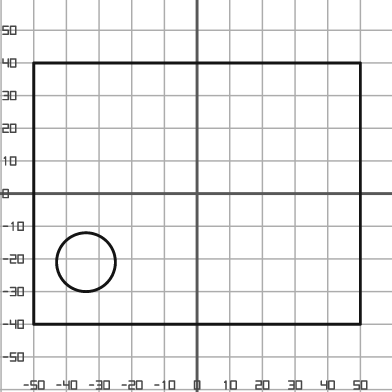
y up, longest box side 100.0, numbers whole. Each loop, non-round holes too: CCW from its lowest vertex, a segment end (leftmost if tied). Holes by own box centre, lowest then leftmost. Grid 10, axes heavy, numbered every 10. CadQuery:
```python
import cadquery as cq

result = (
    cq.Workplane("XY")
    .moveTo(-50.0, -40.0)
    .lineTo(50.0, -40.0)
    .lineTo(50.0, 40.0)
    .lineTo(-50.0, 40.0)
    .close()
    .moveTo(-34.0, -21.0)
    .circle(9.0)
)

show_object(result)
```